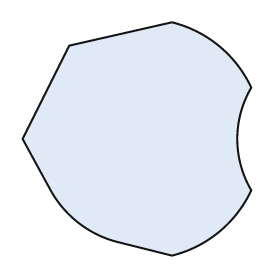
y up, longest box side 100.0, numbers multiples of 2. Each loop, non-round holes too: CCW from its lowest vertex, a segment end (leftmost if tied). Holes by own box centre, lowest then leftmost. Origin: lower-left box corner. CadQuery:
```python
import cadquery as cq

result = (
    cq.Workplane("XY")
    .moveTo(64.0, 0.0)
    .threePointArc((84.0, 10.0), (98.0, 28.0))
    .threePointArc((92.0, 50.0), (98.0, 72.0))
    .threePointArc((84.0, 90.0), (64.0, 100.0))
    .lineTo(20.0, 90.0)
    .lineTo(0.0, 50.0)
    .lineTo(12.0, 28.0)
    .threePointArc((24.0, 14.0), (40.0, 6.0))
    .close()
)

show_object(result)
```